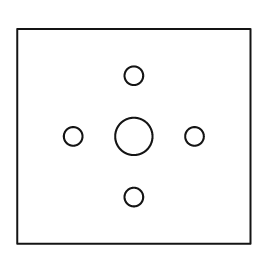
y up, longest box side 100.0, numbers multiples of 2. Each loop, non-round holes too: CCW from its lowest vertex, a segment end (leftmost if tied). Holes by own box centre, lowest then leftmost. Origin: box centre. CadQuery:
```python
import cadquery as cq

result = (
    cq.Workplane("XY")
    .moveTo(-50.0, -46.0)
    .lineTo(50.0, -46.0)
    .lineTo(50.0, 46.0)
    .lineTo(-50.0, 46.0)
    .close()
    .moveTo(0.0, -26.0)
    .circle(4.0)
    .moveTo(-26.0, 0.0)
    .circle(4.0)
    .moveTo(0.0, 0.0)
    .circle(8.0)
    .moveTo(26.0, 0.0)
    .circle(4.0)
    .moveTo(0.0, 26.0)
    .circle(4.0)
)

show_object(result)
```